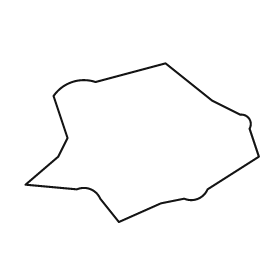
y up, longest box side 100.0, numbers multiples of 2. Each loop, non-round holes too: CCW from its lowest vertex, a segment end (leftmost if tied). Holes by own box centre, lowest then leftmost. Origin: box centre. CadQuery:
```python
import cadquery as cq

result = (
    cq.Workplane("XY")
    .moveTo(-10.0, -34.0)
    .lineTo(8.0, -26.0)
    .lineTo(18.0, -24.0)
    .threePointArc((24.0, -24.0), (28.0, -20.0))
    .lineTo(50.0, -6.0)
    .lineTo(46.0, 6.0)
    .threePointArc((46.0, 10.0), (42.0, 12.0))
    .lineTo(30.0, 18.0)
    .lineTo(10.0, 34.0)
    .lineTo(-20.0, 26.0)
    .threePointArc((-30.0, 26.0), (-38.0, 20.0))
    .lineTo(-32.0, 2.0)
    .lineTo(-36.0, -6.0)
    .lineTo(-50.0, -18.0)
    .lineTo(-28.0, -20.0)
    .threePointArc((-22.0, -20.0), (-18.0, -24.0))
    .close()
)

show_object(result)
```